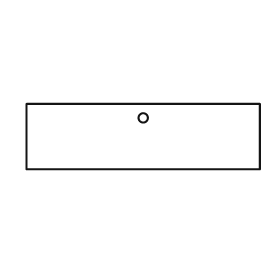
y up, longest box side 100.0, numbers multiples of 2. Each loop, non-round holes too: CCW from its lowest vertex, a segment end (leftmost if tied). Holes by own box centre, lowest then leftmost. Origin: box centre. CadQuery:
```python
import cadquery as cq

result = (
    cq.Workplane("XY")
    .moveTo(-50.0, -14.0)
    .lineTo(50.0, -14.0)
    .lineTo(50.0, 14.0)
    .lineTo(-50.0, 14.0)
    .close()
    .moveTo(0.0, 8.0)
    .circle(2.0)
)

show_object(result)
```